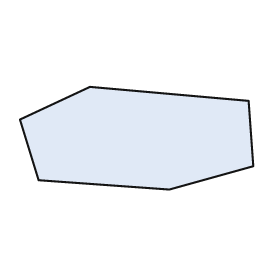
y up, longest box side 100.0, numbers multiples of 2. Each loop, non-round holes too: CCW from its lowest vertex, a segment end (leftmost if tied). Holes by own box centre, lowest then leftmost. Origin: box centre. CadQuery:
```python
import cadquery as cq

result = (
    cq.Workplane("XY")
    .moveTo(14.0, -22.0)
    .lineTo(50.0, -12.0)
    .lineTo(48.0, 16.0)
    .lineTo(-20.0, 22.0)
    .lineTo(-50.0, 8.0)
    .lineTo(-42.0, -18.0)
    .close()
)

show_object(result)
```